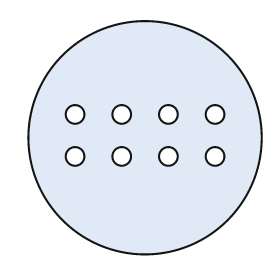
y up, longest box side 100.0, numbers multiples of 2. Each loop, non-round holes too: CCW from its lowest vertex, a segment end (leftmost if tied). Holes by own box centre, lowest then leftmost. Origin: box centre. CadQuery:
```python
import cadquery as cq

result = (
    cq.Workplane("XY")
    .moveTo(0.0, 0.0)
    .circle(50.0)
    .moveTo(-30.0, -8.0)
    .circle(4.0)
    .moveTo(-10.0, -8.0)
    .circle(4.0)
    .moveTo(10.0, -8.0)
    .circle(4.0)
    .moveTo(30.0, -8.0)
    .circle(4.0)
    .moveTo(-30.0, 10.0)
    .circle(4.0)
    .moveTo(-10.0, 10.0)
    .circle(4.0)
    .moveTo(10.0, 10.0)
    .circle(4.0)
    .moveTo(30.0, 10.0)
    .circle(4.0)
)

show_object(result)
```